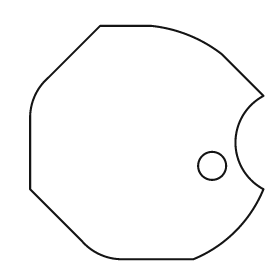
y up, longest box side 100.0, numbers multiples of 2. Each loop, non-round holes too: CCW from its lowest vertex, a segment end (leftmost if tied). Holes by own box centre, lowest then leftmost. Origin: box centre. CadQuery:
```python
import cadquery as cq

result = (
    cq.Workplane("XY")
    .moveTo(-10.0, -50.0)
    .lineTo(20.0, -50.0)
    .threePointArc((38.0, -38.0), (50.0, -20.0))
    .threePointArc((38.0, 0.0), (50.0, 20.0))
    .lineTo(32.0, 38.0)
    .threePointArc((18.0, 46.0), (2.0, 50.0))
    .lineTo(-20.0, 50.0)
    .lineTo(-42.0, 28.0)
    .threePointArc((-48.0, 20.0), (-50.0, 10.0))
    .lineTo(-50.0, -20.0)
    .lineTo(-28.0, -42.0)
    .threePointArc((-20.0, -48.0), (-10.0, -50.0))
    .close()
    .moveTo(28.0, -10.0)
    .circle(6.0)
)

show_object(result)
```